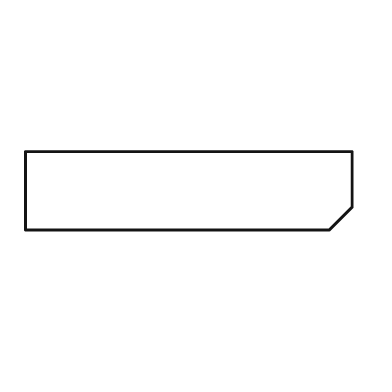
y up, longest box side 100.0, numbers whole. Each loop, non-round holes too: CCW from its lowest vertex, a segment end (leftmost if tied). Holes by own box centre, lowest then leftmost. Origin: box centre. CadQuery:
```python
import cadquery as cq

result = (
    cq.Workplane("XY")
    .moveTo(-50.0, -12.0)
    .lineTo(43.0, -12.0)
    .lineTo(50.0, -5.0)
    .lineTo(50.0, 12.0)
    .lineTo(-50.0, 12.0)
    .close()
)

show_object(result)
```